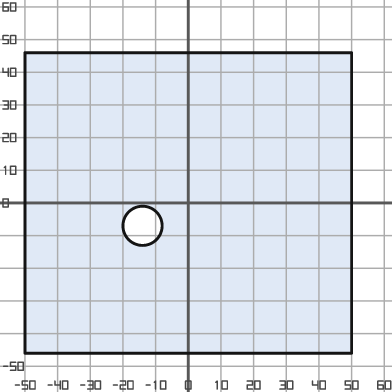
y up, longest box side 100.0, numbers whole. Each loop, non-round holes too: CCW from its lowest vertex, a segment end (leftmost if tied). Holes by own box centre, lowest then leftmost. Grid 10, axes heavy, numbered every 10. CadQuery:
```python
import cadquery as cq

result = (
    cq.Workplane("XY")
    .moveTo(-50.0, -46.0)
    .lineTo(50.0, -46.0)
    .lineTo(50.0, 46.0)
    .lineTo(-50.0, 46.0)
    .close()
    .moveTo(-14.0, -7.0)
    .circle(6.0)
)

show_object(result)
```